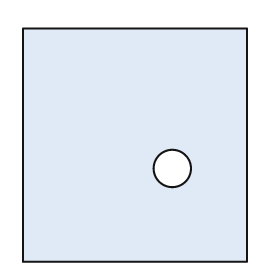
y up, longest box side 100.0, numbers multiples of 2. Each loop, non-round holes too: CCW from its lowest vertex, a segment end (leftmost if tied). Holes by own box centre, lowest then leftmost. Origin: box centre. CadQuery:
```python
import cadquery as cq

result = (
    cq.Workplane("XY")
    .moveTo(-48.0, -50.0)
    .lineTo(48.0, -50.0)
    .lineTo(48.0, 50.0)
    .lineTo(-48.0, 50.0)
    .close()
    .moveTo(16.0, -10.0)
    .circle(8.0)
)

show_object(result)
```